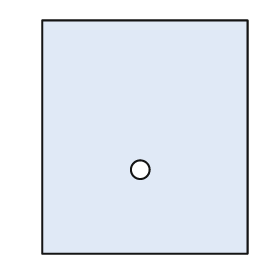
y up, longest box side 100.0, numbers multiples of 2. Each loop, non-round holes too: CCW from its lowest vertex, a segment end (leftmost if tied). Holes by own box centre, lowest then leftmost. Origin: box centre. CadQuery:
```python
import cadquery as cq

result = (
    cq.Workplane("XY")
    .moveTo(-44.0, -50.0)
    .lineTo(44.0, -50.0)
    .lineTo(44.0, 50.0)
    .lineTo(-44.0, 50.0)
    .close()
    .moveTo(-2.0, -14.0)
    .circle(4.0)
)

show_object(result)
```